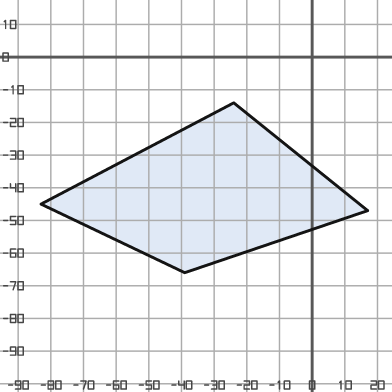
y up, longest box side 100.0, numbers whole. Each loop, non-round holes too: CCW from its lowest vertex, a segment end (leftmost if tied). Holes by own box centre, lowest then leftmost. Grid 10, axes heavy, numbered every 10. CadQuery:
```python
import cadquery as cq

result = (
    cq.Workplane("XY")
    .moveTo(-39.0, -66.0)
    .lineTo(17.0, -47.0)
    .lineTo(-24.0, -14.0)
    .lineTo(-83.0, -45.0)
    .close()
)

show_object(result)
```